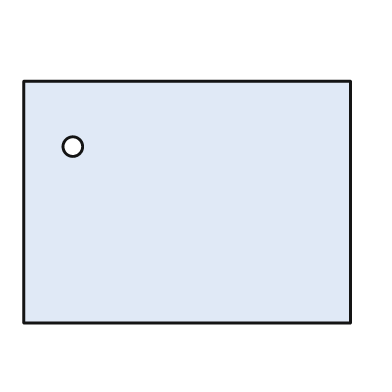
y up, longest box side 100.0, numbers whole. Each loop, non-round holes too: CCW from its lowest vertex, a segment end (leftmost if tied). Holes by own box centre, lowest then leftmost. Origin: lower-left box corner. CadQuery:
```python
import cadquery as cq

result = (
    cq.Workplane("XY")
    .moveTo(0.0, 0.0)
    .lineTo(100.0, 0.0)
    .lineTo(100.0, 74.0)
    .lineTo(0.0, 74.0)
    .close()
    .moveTo(15.0, 54.0)
    .circle(3.0)
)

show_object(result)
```